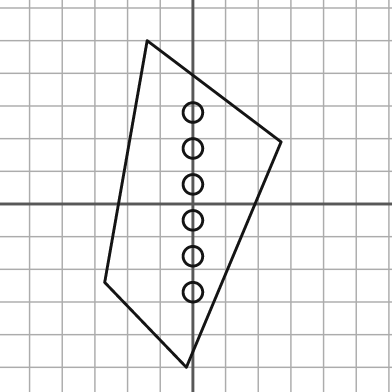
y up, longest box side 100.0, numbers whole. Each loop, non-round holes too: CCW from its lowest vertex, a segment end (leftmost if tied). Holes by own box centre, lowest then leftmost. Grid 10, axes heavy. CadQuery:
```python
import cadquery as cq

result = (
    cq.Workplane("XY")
    .moveTo(-2.0, -50.0)
    .lineTo(27.0, 19.0)
    .lineTo(-14.0, 50.0)
    .lineTo(-27.0, -24.0)
    .close()
    .moveTo(0.0, -27.0)
    .circle(3.0)
    .moveTo(0.0, -16.0)
    .circle(3.0)
    .moveTo(0.0, -5.0)
    .circle(3.0)
    .moveTo(0.0, 6.0)
    .circle(3.0)
    .moveTo(0.0, 17.0)
    .circle(3.0)
    .moveTo(0.0, 28.0)
    .circle(3.0)
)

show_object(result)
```